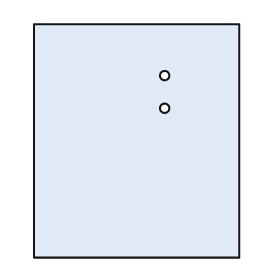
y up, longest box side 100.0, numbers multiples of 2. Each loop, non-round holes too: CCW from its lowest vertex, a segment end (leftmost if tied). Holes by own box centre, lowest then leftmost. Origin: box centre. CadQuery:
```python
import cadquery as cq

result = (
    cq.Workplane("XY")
    .moveTo(-44.0, -50.0)
    .lineTo(44.0, -50.0)
    .lineTo(44.0, 50.0)
    .lineTo(-44.0, 50.0)
    .close()
    .moveTo(12.0, 14.0)
    .circle(2.0)
    .moveTo(12.0, 28.0)
    .circle(2.0)
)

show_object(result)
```